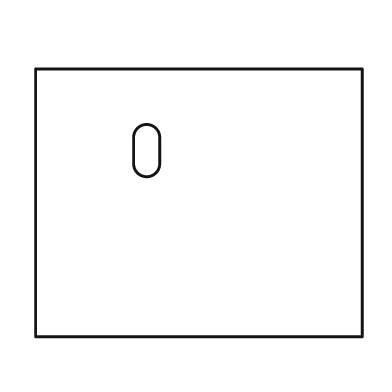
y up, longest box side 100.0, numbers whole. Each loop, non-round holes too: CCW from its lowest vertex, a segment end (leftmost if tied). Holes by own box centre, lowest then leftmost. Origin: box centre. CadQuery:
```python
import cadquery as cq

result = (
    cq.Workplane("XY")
    .moveTo(-50.0, -41.0)
    .lineTo(50.0, -41.0)
    .lineTo(50.0, 41.0)
    .lineTo(-50.0, 41.0)
    .close()
    .moveTo(-20.0, 12.0)
    .threePointArc((-16.0, 8.0), (-12.0, 12.0))
    .lineTo(-12.0, 20.0)
    .threePointArc((-16.0, 24.0), (-20.0, 20.0))
    .close()
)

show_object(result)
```